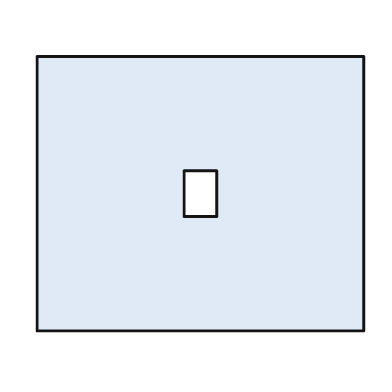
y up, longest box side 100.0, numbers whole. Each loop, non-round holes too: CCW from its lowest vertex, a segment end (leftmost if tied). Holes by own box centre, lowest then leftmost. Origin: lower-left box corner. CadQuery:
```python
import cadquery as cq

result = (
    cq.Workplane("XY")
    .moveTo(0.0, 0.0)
    .lineTo(100.0, 0.0)
    .lineTo(100.0, 84.0)
    .lineTo(0.0, 84.0)
    .close()
    .moveTo(45.0, 35.0)
    .lineTo(55.0, 35.0)
    .lineTo(55.0, 49.0)
    .lineTo(45.0, 49.0)
    .close()
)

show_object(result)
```